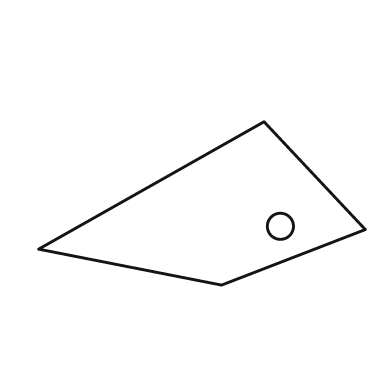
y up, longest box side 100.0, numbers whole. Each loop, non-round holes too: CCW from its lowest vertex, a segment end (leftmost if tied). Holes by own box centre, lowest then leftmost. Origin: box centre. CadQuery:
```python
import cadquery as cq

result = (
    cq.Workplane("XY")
    .moveTo(6.0, -25.0)
    .lineTo(50.0, -8.0)
    .lineTo(19.0, 25.0)
    .lineTo(-50.0, -14.0)
    .close()
    .moveTo(24.0, -7.0)
    .circle(4.0)
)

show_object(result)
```